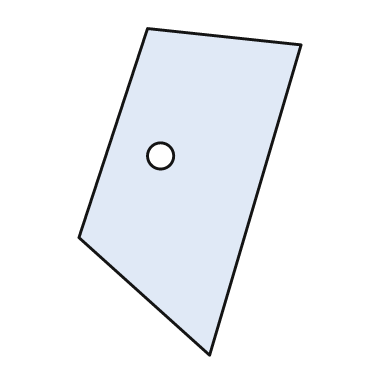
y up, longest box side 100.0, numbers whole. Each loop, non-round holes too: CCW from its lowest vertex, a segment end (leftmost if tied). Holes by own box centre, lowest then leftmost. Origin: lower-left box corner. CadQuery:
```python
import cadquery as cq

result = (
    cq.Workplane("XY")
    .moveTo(40.0, 0.0)
    .lineTo(68.0, 95.0)
    .lineTo(21.0, 100.0)
    .lineTo(0.0, 36.0)
    .close()
    .moveTo(25.0, 61.0)
    .circle(4.0)
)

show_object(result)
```